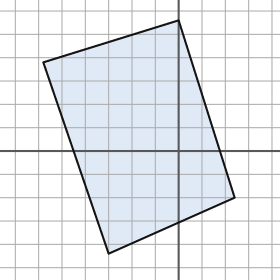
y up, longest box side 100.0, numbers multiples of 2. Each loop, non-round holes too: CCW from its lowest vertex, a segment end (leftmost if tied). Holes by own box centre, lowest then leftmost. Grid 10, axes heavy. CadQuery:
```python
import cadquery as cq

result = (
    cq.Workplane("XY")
    .moveTo(-30.0, -44.0)
    .lineTo(24.0, -20.0)
    .lineTo(0.0, 56.0)
    .lineTo(-58.0, 38.0)
    .close()
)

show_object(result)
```